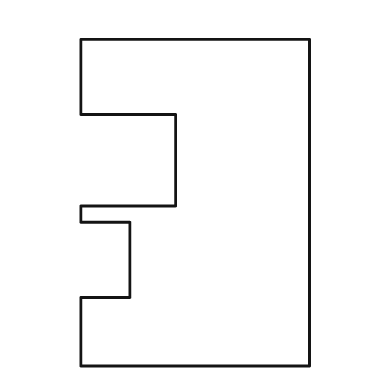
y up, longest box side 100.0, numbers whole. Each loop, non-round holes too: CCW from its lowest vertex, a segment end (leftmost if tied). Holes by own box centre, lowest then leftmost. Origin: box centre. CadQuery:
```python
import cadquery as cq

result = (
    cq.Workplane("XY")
    .moveTo(-35.0, -50.0)
    .lineTo(35.0, -50.0)
    .lineTo(35.0, 50.0)
    .lineTo(-35.0, 50.0)
    .lineTo(-35.0, 27.0)
    .lineTo(-6.0, 27.0)
    .lineTo(-6.0, -1.0)
    .lineTo(-35.0, -1.0)
    .lineTo(-35.0, -6.0)
    .lineTo(-20.0, -6.0)
    .lineTo(-20.0, -29.0)
    .lineTo(-35.0, -29.0)
    .close()
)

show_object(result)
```